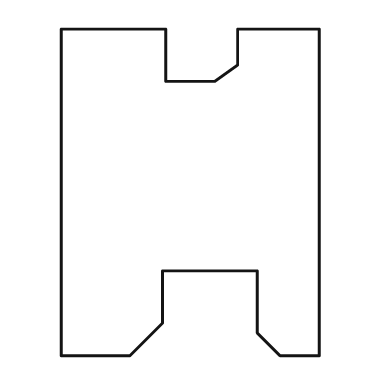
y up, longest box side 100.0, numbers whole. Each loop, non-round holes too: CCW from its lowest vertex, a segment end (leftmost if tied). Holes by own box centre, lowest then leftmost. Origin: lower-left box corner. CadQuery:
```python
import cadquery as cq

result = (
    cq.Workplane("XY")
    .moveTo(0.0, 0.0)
    .lineTo(21.0, 0.0)
    .lineTo(31.0, 10.0)
    .lineTo(31.0, 26.0)
    .lineTo(60.0, 26.0)
    .lineTo(60.0, 7.0)
    .lineTo(67.0, 0.0)
    .lineTo(79.0, 0.0)
    .lineTo(79.0, 100.0)
    .lineTo(54.0, 100.0)
    .lineTo(54.0, 89.0)
    .lineTo(47.0, 84.0)
    .lineTo(32.0, 84.0)
    .lineTo(32.0, 100.0)
    .lineTo(0.0, 100.0)
    .close()
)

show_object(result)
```